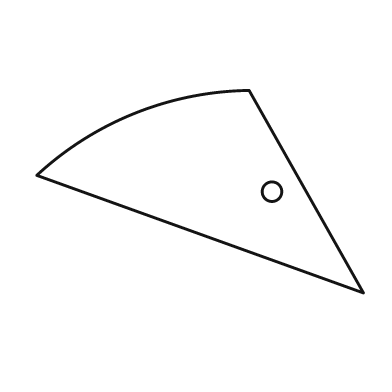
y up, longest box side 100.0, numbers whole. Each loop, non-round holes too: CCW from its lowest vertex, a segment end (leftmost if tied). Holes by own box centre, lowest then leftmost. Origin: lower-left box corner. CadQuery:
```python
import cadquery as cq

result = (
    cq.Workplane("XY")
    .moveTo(100.0, 0.0)
    .lineTo(65.0, 62.0)
    .threePointArc((30.0, 55.0), (0.0, 36.0))
    .close()
    .moveTo(72.0, 31.0)
    .circle(3.0)
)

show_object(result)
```